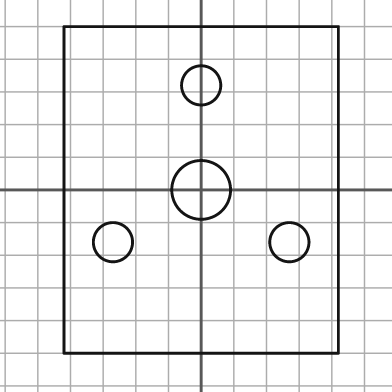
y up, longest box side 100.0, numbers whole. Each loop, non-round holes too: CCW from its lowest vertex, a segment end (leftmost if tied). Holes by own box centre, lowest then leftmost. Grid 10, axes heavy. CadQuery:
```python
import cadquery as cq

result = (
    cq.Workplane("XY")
    .moveTo(-42.0, -50.0)
    .lineTo(42.0, -50.0)
    .lineTo(42.0, 50.0)
    .lineTo(-42.0, 50.0)
    .close()
    .moveTo(-27.0, -16.0)
    .circle(6.0)
    .moveTo(27.0, -16.0)
    .circle(6.0)
    .moveTo(0.0, 0.0)
    .circle(9.0)
    .moveTo(0.0, 32.0)
    .circle(6.0)
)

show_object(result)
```